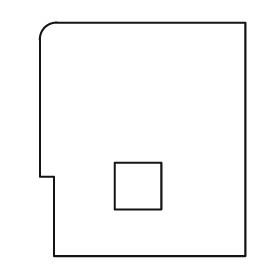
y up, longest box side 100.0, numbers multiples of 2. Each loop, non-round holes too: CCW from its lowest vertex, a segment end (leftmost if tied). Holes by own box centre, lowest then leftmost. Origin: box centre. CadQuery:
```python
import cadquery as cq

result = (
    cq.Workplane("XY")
    .moveTo(-38.0, -50.0)
    .lineTo(44.0, -50.0)
    .lineTo(44.0, 50.0)
    .lineTo(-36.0, 50.0)
    .threePointArc((-42.0, 48.0), (-44.0, 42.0))
    .lineTo(-44.0, -16.0)
    .lineTo(-38.0, -16.0)
    .close()
    .moveTo(-12.0, -30.0)
    .lineTo(8.0, -30.0)
    .lineTo(8.0, -10.0)
    .lineTo(-12.0, -10.0)
    .close()
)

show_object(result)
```